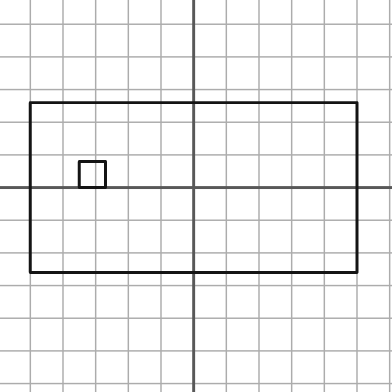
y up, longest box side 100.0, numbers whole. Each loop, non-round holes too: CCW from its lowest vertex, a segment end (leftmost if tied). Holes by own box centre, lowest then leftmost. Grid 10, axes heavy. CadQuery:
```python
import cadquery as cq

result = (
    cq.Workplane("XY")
    .moveTo(-50.0, -26.0)
    .lineTo(50.0, -26.0)
    .lineTo(50.0, 26.0)
    .lineTo(-50.0, 26.0)
    .close()
    .moveTo(-35.0, 0.0)
    .lineTo(-27.0, 0.0)
    .lineTo(-27.0, 8.0)
    .lineTo(-35.0, 8.0)
    .close()
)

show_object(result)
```